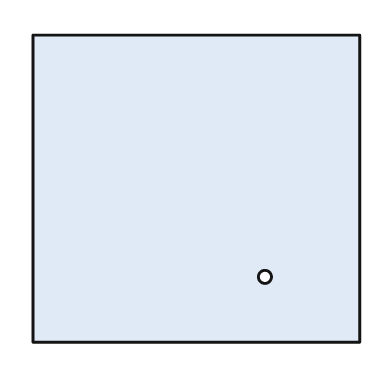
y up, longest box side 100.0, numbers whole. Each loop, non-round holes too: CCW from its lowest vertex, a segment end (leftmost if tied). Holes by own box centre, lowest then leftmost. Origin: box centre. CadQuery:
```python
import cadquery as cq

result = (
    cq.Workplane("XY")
    .moveTo(-50.0, -47.0)
    .lineTo(50.0, -47.0)
    .lineTo(50.0, 47.0)
    .lineTo(-50.0, 47.0)
    .close()
    .moveTo(21.0, -27.0)
    .circle(2.0)
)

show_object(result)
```